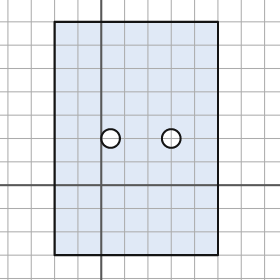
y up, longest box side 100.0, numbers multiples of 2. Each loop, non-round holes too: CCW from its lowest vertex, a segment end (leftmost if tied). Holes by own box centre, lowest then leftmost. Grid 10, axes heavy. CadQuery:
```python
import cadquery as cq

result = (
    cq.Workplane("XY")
    .moveTo(-20.0, -30.0)
    .lineTo(50.0, -30.0)
    .lineTo(50.0, 70.0)
    .lineTo(-20.0, 70.0)
    .close()
    .moveTo(4.0, 20.0)
    .circle(4.0)
    .moveTo(30.0, 20.0)
    .circle(4.0)
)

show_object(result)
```